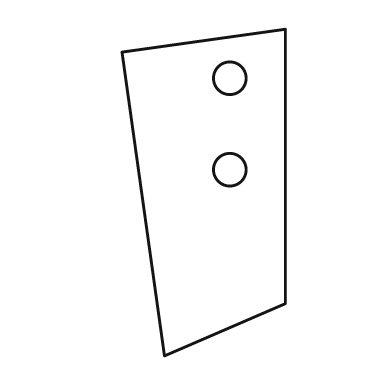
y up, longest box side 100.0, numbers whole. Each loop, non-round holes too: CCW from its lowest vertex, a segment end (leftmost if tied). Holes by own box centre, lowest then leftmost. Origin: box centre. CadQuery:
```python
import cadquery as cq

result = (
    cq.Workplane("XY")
    .moveTo(-12.0, -50.0)
    .lineTo(25.0, -34.0)
    .lineTo(25.0, 50.0)
    .lineTo(-25.0, 43.0)
    .close()
    .moveTo(8.0, 7.0)
    .circle(5.0)
    .moveTo(8.0, 35.0)
    .circle(5.0)
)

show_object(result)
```